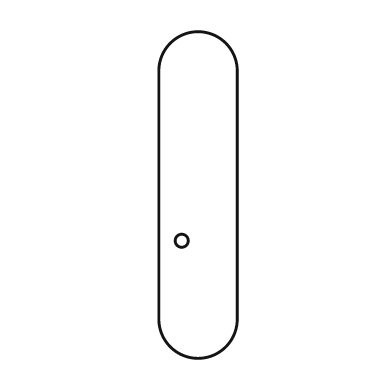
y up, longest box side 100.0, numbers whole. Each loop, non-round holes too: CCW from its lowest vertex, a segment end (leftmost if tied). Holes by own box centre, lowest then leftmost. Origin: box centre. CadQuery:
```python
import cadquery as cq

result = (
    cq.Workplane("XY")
    .moveTo(-12.0, -38.0)
    .threePointArc((0.0, -50.0), (12.0, -38.0))
    .lineTo(12.0, 38.0)
    .threePointArc((0.0, 50.0), (-12.0, 38.0))
    .close()
    .moveTo(-5.0, -14.0)
    .circle(2.0)
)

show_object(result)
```